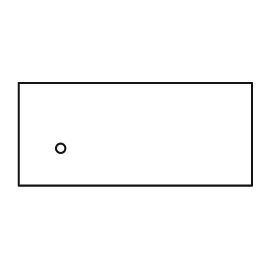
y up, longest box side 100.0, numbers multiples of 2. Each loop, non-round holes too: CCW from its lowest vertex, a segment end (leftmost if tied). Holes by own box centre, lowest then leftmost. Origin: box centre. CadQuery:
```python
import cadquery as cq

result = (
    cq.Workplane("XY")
    .moveTo(-50.0, -22.0)
    .lineTo(50.0, -22.0)
    .lineTo(50.0, 22.0)
    .lineTo(-50.0, 22.0)
    .close()
    .moveTo(-32.0, -6.0)
    .circle(2.0)
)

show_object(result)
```